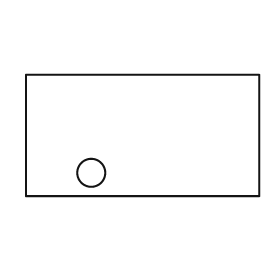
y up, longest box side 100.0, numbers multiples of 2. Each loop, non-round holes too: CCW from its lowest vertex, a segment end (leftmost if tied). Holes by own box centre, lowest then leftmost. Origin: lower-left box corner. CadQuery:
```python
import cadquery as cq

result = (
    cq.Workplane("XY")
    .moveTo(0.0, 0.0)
    .lineTo(100.0, 0.0)
    .lineTo(100.0, 52.0)
    .lineTo(0.0, 52.0)
    .close()
    .moveTo(28.0, 10.0)
    .circle(6.0)
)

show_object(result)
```